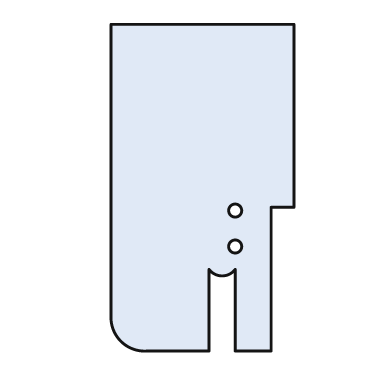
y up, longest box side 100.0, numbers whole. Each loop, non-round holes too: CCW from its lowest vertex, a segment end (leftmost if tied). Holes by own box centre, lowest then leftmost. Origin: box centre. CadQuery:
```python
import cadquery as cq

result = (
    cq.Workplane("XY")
    .moveTo(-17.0, -50.0)
    .lineTo(2.0, -50.0)
    .lineTo(2.0, -25.0)
    .threePointArc((6.0, -27.0), (10.0, -25.0))
    .lineTo(10.0, -50.0)
    .lineTo(21.0, -50.0)
    .lineTo(21.0, -6.0)
    .lineTo(28.0, -6.0)
    .lineTo(28.0, 50.0)
    .lineTo(-28.0, 50.0)
    .lineTo(-28.0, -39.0)
    .threePointArc((-25.0, -47.0), (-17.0, -50.0))
    .close()
    .moveTo(10.0, -18.0)
    .circle(2.0)
    .moveTo(10.0, -7.0)
    .circle(2.0)
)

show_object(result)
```